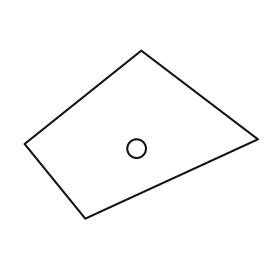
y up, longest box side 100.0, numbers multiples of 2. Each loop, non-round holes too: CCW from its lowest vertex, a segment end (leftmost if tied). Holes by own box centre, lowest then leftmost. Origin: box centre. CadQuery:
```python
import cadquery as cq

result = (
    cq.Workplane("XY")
    .moveTo(-24.0, -36.0)
    .lineTo(50.0, -2.0)
    .lineTo(0.0, 36.0)
    .lineTo(-50.0, -4.0)
    .close()
    .moveTo(-2.0, -6.0)
    .circle(4.0)
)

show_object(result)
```